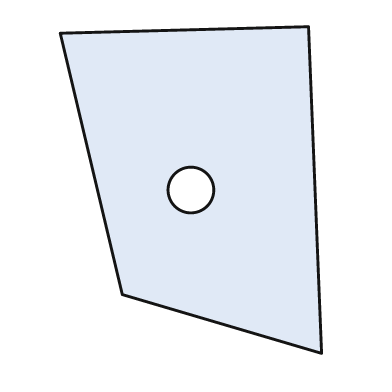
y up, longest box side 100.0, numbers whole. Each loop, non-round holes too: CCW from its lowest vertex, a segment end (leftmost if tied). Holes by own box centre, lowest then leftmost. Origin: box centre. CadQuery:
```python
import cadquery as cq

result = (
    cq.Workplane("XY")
    .moveTo(40.0, -50.0)
    .lineTo(36.0, 50.0)
    .lineTo(-40.0, 48.0)
    .lineTo(-21.0, -32.0)
    .close()
    .moveTo(0.0, 0.0)
    .circle(7.0)
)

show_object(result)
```